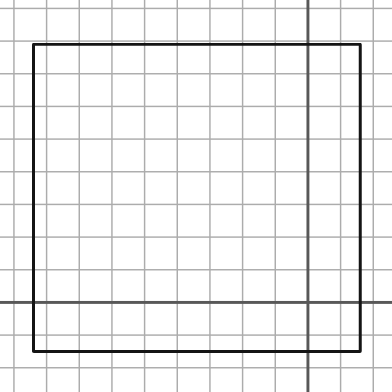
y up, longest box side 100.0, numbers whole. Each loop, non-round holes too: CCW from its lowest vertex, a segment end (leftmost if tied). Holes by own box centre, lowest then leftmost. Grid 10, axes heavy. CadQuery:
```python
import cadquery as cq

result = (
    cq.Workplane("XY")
    .moveTo(-84.0, -15.0)
    .lineTo(16.0, -15.0)
    .lineTo(16.0, 79.0)
    .lineTo(-84.0, 79.0)
    .close()
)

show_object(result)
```